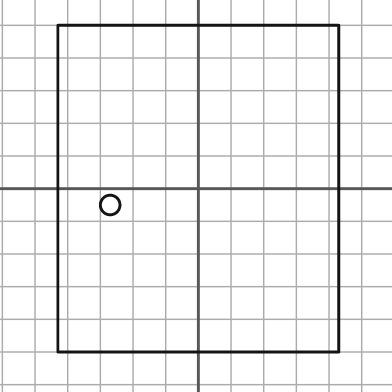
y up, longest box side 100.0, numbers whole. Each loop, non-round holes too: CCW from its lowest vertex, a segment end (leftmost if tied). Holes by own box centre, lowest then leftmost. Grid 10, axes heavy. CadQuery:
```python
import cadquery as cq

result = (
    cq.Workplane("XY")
    .moveTo(-43.0, -50.0)
    .lineTo(43.0, -50.0)
    .lineTo(43.0, 50.0)
    .lineTo(-43.0, 50.0)
    .close()
    .moveTo(-27.0, -5.0)
    .circle(3.0)
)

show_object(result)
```